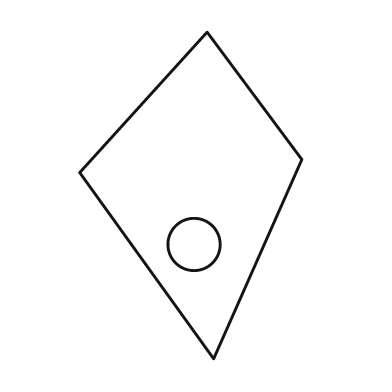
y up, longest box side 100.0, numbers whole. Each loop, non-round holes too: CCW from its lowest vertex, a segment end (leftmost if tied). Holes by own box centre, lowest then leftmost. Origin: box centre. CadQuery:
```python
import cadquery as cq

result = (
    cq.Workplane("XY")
    .moveTo(7.0, -50.0)
    .lineTo(34.0, 11.0)
    .lineTo(5.0, 50.0)
    .lineTo(-34.0, 7.0)
    .close()
    .moveTo(1.0, -15.0)
    .circle(8.0)
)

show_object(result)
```